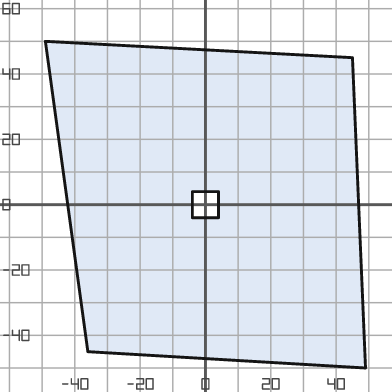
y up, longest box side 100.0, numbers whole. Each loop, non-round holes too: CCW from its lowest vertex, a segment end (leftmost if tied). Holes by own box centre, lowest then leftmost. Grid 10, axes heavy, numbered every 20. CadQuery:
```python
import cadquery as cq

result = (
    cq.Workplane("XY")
    .moveTo(49.0, -50.0)
    .lineTo(45.0, 45.0)
    .lineTo(-49.0, 50.0)
    .lineTo(-36.0, -45.0)
    .close()
    .moveTo(-4.0, -4.0)
    .lineTo(4.0, -4.0)
    .lineTo(4.0, 4.0)
    .lineTo(-4.0, 4.0)
    .close()
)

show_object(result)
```